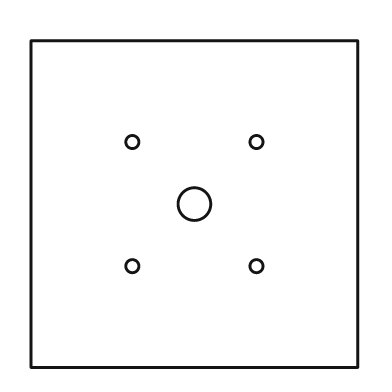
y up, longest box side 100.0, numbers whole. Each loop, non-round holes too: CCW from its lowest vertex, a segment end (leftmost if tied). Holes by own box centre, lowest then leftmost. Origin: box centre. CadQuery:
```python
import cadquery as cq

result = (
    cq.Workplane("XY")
    .moveTo(-50.0, -50.0)
    .lineTo(50.0, -50.0)
    .lineTo(50.0, 50.0)
    .lineTo(-50.0, 50.0)
    .close()
    .moveTo(-19.0, -19.0)
    .circle(2.0)
    .moveTo(19.0, -19.0)
    .circle(2.0)
    .moveTo(0.0, 0.0)
    .circle(5.0)
    .moveTo(-19.0, 19.0)
    .circle(2.0)
    .moveTo(19.0, 19.0)
    .circle(2.0)
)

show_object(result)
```